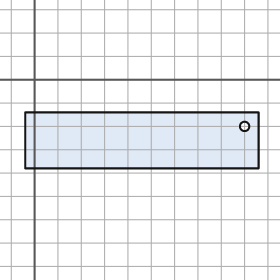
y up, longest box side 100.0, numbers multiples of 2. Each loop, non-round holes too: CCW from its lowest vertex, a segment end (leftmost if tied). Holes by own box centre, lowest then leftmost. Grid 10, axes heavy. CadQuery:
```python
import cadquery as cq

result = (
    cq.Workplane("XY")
    .moveTo(-4.0, -38.0)
    .lineTo(96.0, -38.0)
    .lineTo(96.0, -14.0)
    .lineTo(-4.0, -14.0)
    .close()
    .moveTo(90.0, -20.0)
    .circle(2.0)
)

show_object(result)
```